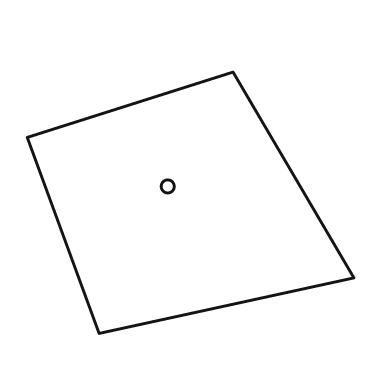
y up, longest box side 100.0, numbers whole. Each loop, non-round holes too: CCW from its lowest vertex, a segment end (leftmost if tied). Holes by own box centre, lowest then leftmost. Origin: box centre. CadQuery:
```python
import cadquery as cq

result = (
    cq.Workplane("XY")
    .moveTo(-28.0, -40.0)
    .lineTo(50.0, -23.0)
    .lineTo(13.0, 40.0)
    .lineTo(-50.0, 20.0)
    .close()
    .moveTo(-7.0, 5.0)
    .circle(2.0)
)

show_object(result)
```